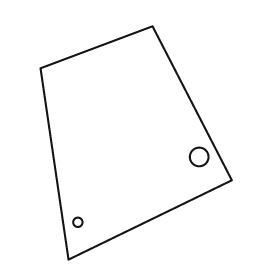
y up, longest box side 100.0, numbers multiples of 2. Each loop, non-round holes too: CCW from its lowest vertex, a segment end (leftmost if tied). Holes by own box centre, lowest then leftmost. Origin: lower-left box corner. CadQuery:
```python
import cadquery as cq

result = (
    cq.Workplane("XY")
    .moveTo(12.0, 0.0)
    .lineTo(82.0, 34.0)
    .lineTo(48.0, 100.0)
    .lineTo(0.0, 82.0)
    .close()
    .moveTo(16.0, 16.0)
    .circle(2.0)
    .moveTo(68.0, 44.0)
    .circle(4.0)
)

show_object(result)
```